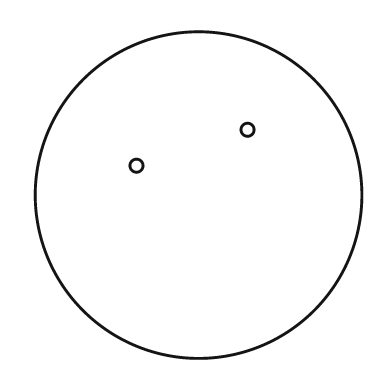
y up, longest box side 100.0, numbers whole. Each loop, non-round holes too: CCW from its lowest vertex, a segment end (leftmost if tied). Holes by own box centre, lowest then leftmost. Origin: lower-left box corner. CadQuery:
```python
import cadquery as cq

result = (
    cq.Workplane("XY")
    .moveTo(50.0, 50.0)
    .circle(50.0)
    .moveTo(31.0, 59.0)
    .circle(2.0)
    .moveTo(65.0, 70.0)
    .circle(2.0)
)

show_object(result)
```